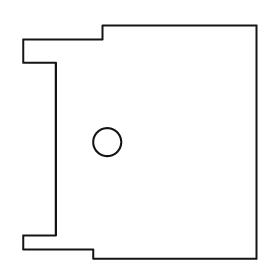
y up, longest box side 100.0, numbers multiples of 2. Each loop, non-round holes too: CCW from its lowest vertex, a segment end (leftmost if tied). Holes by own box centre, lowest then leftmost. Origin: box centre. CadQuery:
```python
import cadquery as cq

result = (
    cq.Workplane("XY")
    .moveTo(-20.0, -50.0)
    .lineTo(50.0, -50.0)
    .lineTo(50.0, 50.0)
    .lineTo(-16.0, 50.0)
    .lineTo(-16.0, 44.0)
    .lineTo(-50.0, 44.0)
    .lineTo(-50.0, 34.0)
    .lineTo(-36.0, 34.0)
    .lineTo(-36.0, -40.0)
    .lineTo(-50.0, -40.0)
    .lineTo(-50.0, -46.0)
    .lineTo(-20.0, -46.0)
    .close()
    .moveTo(-14.0, 0.0)
    .circle(6.0)
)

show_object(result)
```